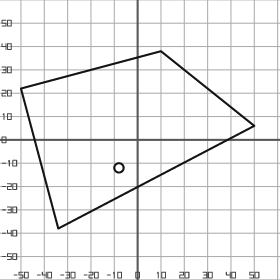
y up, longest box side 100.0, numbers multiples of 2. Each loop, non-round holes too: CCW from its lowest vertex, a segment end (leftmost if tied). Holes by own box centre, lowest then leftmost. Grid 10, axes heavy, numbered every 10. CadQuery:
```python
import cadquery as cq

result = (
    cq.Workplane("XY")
    .moveTo(-34.0, -38.0)
    .lineTo(50.0, 6.0)
    .lineTo(10.0, 38.0)
    .lineTo(-50.0, 22.0)
    .close()
    .moveTo(-8.0, -12.0)
    .circle(2.0)
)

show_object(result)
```